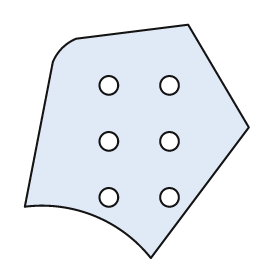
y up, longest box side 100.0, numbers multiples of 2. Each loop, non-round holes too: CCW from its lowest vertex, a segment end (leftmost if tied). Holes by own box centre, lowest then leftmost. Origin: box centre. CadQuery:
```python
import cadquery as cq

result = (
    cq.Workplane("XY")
    .moveTo(6.0, -50.0)
    .lineTo(48.0, 6.0)
    .lineTo(22.0, 50.0)
    .lineTo(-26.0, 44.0)
    .threePointArc((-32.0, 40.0), (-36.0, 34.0))
    .lineTo(-48.0, -28.0)
    .threePointArc((-18.0, -32.0), (6.0, -50.0))
    .close()
    .moveTo(-12.0, -24.0)
    .circle(4.0)
    .moveTo(14.0, -24.0)
    .circle(4.0)
    .moveTo(-12.0, 0.0)
    .circle(4.0)
    .moveTo(14.0, 0.0)
    .circle(4.0)
    .moveTo(-12.0, 24.0)
    .circle(4.0)
    .moveTo(14.0, 24.0)
    .circle(4.0)
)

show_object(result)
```